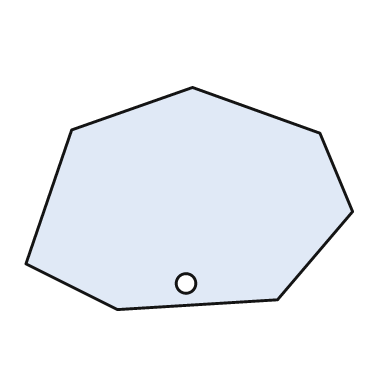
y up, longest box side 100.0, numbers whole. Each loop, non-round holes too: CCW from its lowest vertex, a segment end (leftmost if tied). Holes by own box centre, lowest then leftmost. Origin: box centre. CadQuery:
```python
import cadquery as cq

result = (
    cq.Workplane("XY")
    .moveTo(-22.0, -34.0)
    .lineTo(27.0, -31.0)
    .lineTo(50.0, -4.0)
    .lineTo(40.0, 20.0)
    .lineTo(1.0, 34.0)
    .lineTo(-36.0, 21.0)
    .lineTo(-50.0, -20.0)
    .close()
    .moveTo(-1.0, -26.0)
    .circle(3.0)
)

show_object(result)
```